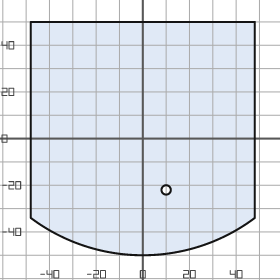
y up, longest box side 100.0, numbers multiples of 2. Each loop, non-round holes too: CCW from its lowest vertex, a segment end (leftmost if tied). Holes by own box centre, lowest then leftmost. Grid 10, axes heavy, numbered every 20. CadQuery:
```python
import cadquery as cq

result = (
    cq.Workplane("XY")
    .moveTo(-48.0, -34.0)
    .threePointArc((0.0, -50.0), (48.0, -34.0))
    .lineTo(48.0, 50.0)
    .lineTo(-48.0, 50.0)
    .close()
    .moveTo(10.0, -22.0)
    .circle(2.0)
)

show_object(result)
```